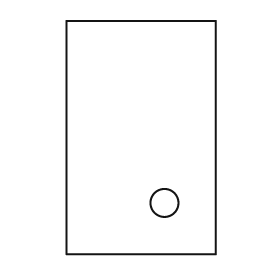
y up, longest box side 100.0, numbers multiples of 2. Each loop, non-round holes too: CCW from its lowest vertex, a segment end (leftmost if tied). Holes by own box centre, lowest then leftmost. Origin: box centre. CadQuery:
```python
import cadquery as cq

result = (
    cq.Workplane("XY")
    .moveTo(-32.0, -50.0)
    .lineTo(32.0, -50.0)
    .lineTo(32.0, 50.0)
    .lineTo(-32.0, 50.0)
    .close()
    .moveTo(10.0, -28.0)
    .circle(6.0)
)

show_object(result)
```